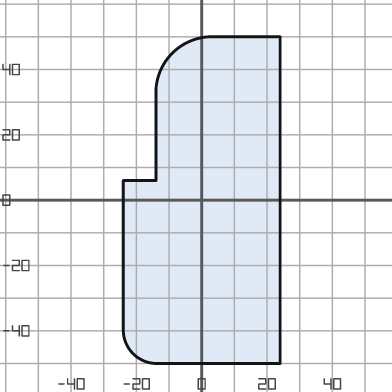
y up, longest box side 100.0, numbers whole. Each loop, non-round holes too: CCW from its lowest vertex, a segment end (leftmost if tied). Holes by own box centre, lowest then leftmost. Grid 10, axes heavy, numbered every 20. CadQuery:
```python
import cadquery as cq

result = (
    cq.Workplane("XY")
    .moveTo(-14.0, -50.0)
    .lineTo(24.0, -50.0)
    .lineTo(24.0, 50.0)
    .lineTo(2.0, 50.0)
    .threePointArc((-9.0, 45.0), (-14.0, 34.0))
    .lineTo(-14.0, 6.0)
    .lineTo(-24.0, 6.0)
    .lineTo(-24.0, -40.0)
    .threePointArc((-21.0, -47.0), (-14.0, -50.0))
    .close()
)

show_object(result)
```